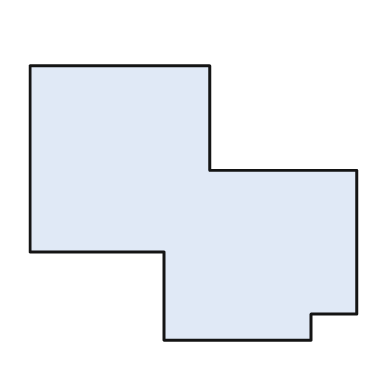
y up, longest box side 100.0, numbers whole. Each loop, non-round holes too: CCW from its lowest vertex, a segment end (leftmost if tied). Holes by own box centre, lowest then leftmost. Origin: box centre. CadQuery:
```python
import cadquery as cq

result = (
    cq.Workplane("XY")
    .moveTo(-9.0, -42.0)
    .lineTo(36.0, -42.0)
    .lineTo(36.0, -34.0)
    .lineTo(50.0, -34.0)
    .lineTo(50.0, 10.0)
    .lineTo(5.0, 10.0)
    .lineTo(5.0, 42.0)
    .lineTo(-50.0, 42.0)
    .lineTo(-50.0, -15.0)
    .lineTo(-9.0, -15.0)
    .close()
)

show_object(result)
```